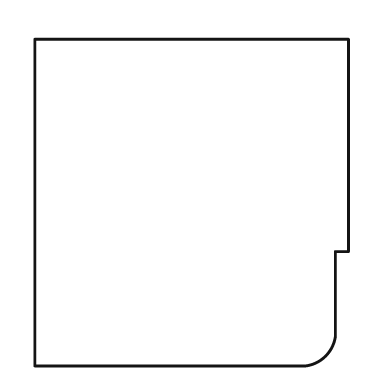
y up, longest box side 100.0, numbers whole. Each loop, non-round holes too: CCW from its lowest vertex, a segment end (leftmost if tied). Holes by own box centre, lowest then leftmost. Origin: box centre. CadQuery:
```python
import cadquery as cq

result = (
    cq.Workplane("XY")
    .moveTo(-48.0, -50.0)
    .lineTo(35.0, -50.0)
    .threePointArc((41.0, -47.0), (44.0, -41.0))
    .lineTo(44.0, -15.0)
    .lineTo(48.0, -15.0)
    .lineTo(48.0, 50.0)
    .lineTo(-48.0, 50.0)
    .close()
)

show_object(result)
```